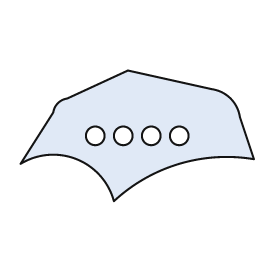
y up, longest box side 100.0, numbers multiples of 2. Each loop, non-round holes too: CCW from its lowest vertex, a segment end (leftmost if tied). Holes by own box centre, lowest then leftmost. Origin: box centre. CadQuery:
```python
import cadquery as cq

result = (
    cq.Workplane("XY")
    .moveTo(-10.0, -28.0)
    .threePointArc((18.0, -12.0), (50.0, -10.0))
    .lineTo(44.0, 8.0)
    .threePointArc((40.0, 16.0), (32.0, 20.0))
    .lineTo(-4.0, 28.0)
    .lineTo(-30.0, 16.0)
    .threePointArc((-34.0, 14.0), (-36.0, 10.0))
    .lineTo(-50.0, -12.0)
    .threePointArc((-26.0, -10.0), (-10.0, -28.0))
    .close()
    .moveTo(-18.0, 0.0)
    .circle(4.0)
    .moveTo(-6.0, 0.0)
    .circle(4.0)
    .moveTo(6.0, 0.0)
    .circle(4.0)
    .moveTo(18.0, 0.0)
    .circle(4.0)
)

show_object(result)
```